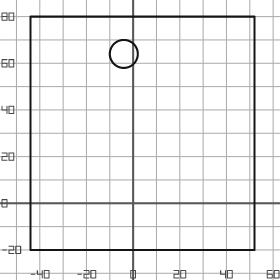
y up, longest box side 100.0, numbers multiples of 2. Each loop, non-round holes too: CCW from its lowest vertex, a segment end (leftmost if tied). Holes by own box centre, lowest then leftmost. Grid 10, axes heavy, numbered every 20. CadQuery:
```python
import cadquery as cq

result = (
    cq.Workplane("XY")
    .moveTo(-44.0, -20.0)
    .lineTo(52.0, -20.0)
    .lineTo(52.0, 80.0)
    .lineTo(-44.0, 80.0)
    .close()
    .moveTo(-4.0, 64.0)
    .circle(6.0)
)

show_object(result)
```